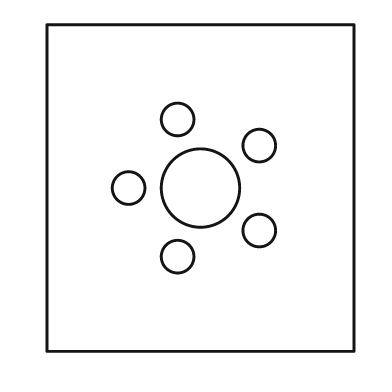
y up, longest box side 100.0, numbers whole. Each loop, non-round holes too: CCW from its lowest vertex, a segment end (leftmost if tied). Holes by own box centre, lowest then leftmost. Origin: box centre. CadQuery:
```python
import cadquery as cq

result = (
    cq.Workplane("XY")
    .moveTo(-47.0, -50.0)
    .lineTo(47.0, -50.0)
    .lineTo(47.0, 50.0)
    .lineTo(-47.0, 50.0)
    .close()
    .moveTo(-7.0, -21.0)
    .circle(5.0)
    .moveTo(18.0, -13.0)
    .circle(5.0)
    .moveTo(-22.0, 0.0)
    .circle(5.0)
    .moveTo(0.0, 0.0)
    .circle(12.0)
    .moveTo(18.0, 13.0)
    .circle(5.0)
    .moveTo(-7.0, 21.0)
    .circle(5.0)
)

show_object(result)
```